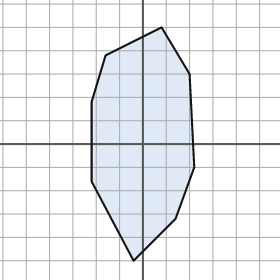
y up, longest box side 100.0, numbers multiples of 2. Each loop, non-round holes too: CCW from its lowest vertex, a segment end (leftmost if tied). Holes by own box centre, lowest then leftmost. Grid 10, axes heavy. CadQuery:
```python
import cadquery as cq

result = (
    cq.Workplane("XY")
    .moveTo(-4.0, -50.0)
    .lineTo(14.0, -32.0)
    .lineTo(22.0, -10.0)
    .lineTo(20.0, 30.0)
    .lineTo(8.0, 50.0)
    .lineTo(-16.0, 38.0)
    .lineTo(-22.0, 18.0)
    .lineTo(-22.0, -16.0)
    .close()
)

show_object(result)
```